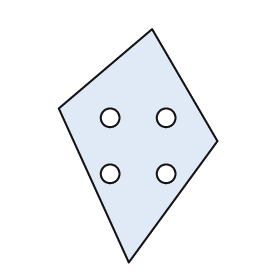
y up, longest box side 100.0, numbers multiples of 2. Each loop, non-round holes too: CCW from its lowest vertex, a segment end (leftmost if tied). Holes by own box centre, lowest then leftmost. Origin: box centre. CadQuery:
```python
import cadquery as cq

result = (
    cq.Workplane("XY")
    .moveTo(-4.0, -50.0)
    .lineTo(34.0, 2.0)
    .lineTo(6.0, 50.0)
    .lineTo(-34.0, 16.0)
    .close()
    .moveTo(-12.0, -12.0)
    .circle(4.0)
    .moveTo(12.0, -12.0)
    .circle(4.0)
    .moveTo(-12.0, 12.0)
    .circle(4.0)
    .moveTo(12.0, 12.0)
    .circle(4.0)
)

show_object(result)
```